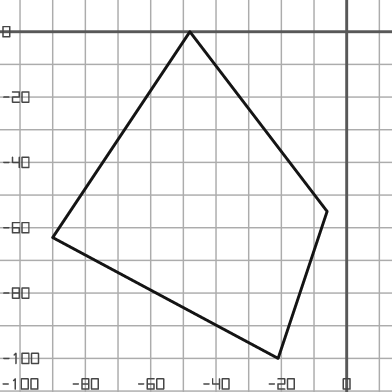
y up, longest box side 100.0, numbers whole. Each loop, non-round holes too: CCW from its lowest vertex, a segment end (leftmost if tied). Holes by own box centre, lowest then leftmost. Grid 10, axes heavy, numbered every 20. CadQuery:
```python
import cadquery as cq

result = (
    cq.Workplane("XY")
    .moveTo(-21.0, -100.0)
    .lineTo(-6.0, -55.0)
    .lineTo(-48.0, 0.0)
    .lineTo(-90.0, -63.0)
    .close()
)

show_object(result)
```